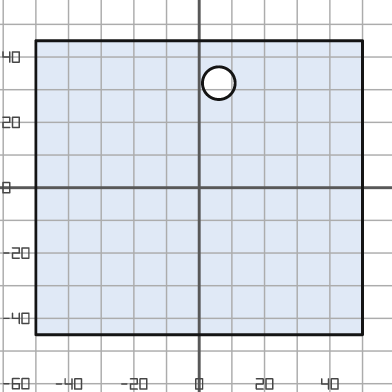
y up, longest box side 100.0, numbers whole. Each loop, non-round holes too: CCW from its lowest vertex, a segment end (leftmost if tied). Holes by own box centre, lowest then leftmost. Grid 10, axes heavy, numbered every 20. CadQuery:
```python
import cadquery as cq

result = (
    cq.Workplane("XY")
    .moveTo(-50.0, -45.0)
    .lineTo(50.0, -45.0)
    .lineTo(50.0, 45.0)
    .lineTo(-50.0, 45.0)
    .close()
    .moveTo(6.0, 32.0)
    .circle(5.0)
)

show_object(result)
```